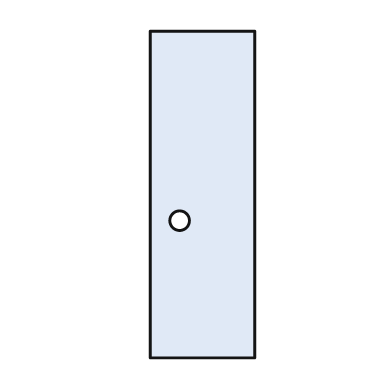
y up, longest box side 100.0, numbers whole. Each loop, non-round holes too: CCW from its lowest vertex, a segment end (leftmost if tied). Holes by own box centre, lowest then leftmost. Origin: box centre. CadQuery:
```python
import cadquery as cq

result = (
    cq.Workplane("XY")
    .moveTo(-16.0, -50.0)
    .lineTo(16.0, -50.0)
    .lineTo(16.0, 50.0)
    .lineTo(-16.0, 50.0)
    .close()
    .moveTo(-7.0, -8.0)
    .circle(3.0)
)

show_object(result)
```